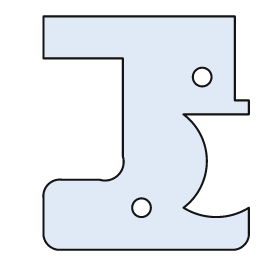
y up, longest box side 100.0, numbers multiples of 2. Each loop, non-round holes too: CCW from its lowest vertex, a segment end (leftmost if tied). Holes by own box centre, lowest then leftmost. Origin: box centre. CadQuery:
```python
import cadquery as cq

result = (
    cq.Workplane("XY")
    .moveTo(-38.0, -50.0)
    .lineTo(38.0, -50.0)
    .threePointArc((42.0, -48.0), (44.0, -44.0))
    .lineTo(44.0, -32.0)
    .threePointArc((30.0, -36.0), (16.0, -32.0))
    .threePointArc((26.0, -12.0), (16.0, 8.0))
    .lineTo(44.0, 8.0)
    .lineTo(44.0, 14.0)
    .lineTo(38.0, 14.0)
    .lineTo(38.0, 50.0)
    .lineTo(-44.0, 50.0)
    .lineTo(-44.0, 32.0)
    .lineTo(-10.0, 32.0)
    .lineTo(-10.0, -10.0)
    .threePointArc((-12.0, -18.0), (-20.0, -20.0))
    .lineTo(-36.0, -20.0)
    .threePointArc((-42.0, -22.0), (-44.0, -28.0))
    .lineTo(-44.0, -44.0)
    .threePointArc((-42.0, -48.0), (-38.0, -50.0))
    .close()
    .moveTo(-2.0, -32.0)
    .circle(4.0)
    .moveTo(24.0, 24.0)
    .circle(4.0)
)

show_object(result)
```